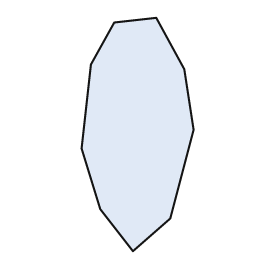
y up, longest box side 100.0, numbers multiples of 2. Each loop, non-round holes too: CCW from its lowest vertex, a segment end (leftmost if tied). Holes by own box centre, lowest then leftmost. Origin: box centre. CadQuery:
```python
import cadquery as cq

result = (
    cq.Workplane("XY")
    .moveTo(-2.0, -50.0)
    .lineTo(14.0, -36.0)
    .lineTo(24.0, 2.0)
    .lineTo(20.0, 28.0)
    .lineTo(8.0, 50.0)
    .lineTo(-10.0, 48.0)
    .lineTo(-20.0, 30.0)
    .lineTo(-24.0, -6.0)
    .lineTo(-16.0, -32.0)
    .close()
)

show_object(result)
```